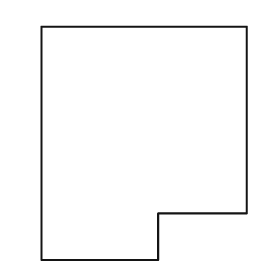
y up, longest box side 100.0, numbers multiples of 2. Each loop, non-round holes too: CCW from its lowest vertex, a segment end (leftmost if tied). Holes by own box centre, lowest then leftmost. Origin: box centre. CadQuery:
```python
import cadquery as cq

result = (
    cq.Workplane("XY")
    .moveTo(-44.0, -50.0)
    .lineTo(6.0, -50.0)
    .lineTo(6.0, -30.0)
    .lineTo(44.0, -30.0)
    .lineTo(44.0, 50.0)
    .lineTo(-44.0, 50.0)
    .close()
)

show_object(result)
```